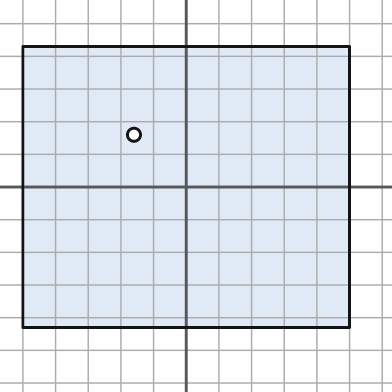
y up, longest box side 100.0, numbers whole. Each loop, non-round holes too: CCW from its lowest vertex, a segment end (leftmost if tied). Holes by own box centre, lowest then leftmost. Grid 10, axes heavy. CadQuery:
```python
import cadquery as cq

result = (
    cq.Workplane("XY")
    .moveTo(-50.0, -43.0)
    .lineTo(50.0, -43.0)
    .lineTo(50.0, 43.0)
    .lineTo(-50.0, 43.0)
    .close()
    .moveTo(-16.0, 16.0)
    .circle(2.0)
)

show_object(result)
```